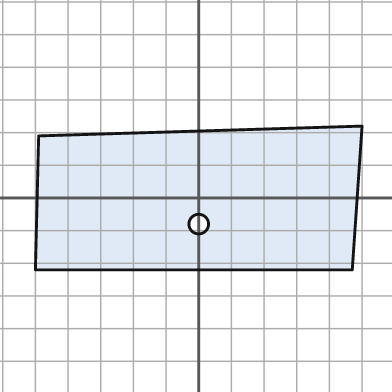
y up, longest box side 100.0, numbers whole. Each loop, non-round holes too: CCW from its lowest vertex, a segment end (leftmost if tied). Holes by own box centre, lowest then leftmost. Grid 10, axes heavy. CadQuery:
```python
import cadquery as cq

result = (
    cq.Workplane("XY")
    .moveTo(-50.0, -22.0)
    .lineTo(47.0, -22.0)
    .lineTo(50.0, 22.0)
    .lineTo(-49.0, 19.0)
    .close()
    .moveTo(0.0, -8.0)
    .circle(3.0)
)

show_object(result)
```